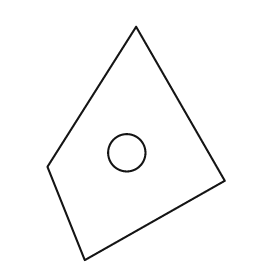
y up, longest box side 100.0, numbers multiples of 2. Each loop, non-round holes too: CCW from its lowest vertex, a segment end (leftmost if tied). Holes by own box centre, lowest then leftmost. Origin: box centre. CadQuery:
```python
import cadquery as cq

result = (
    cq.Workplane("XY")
    .moveTo(-22.0, -50.0)
    .lineTo(38.0, -16.0)
    .lineTo(0.0, 50.0)
    .lineTo(-38.0, -10.0)
    .close()
    .moveTo(-4.0, -4.0)
    .circle(8.0)
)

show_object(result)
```